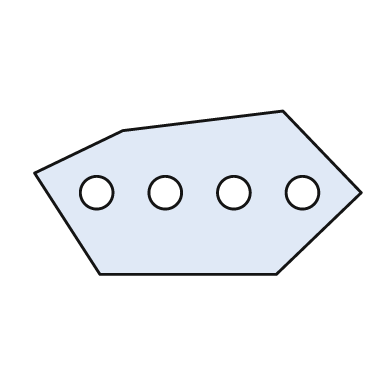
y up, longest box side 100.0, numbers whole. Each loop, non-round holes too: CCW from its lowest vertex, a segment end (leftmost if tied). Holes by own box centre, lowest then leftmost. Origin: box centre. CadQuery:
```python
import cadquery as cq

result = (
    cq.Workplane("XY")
    .moveTo(-30.0, -25.0)
    .lineTo(24.0, -25.0)
    .lineTo(50.0, 0.0)
    .lineTo(26.0, 25.0)
    .lineTo(-23.0, 19.0)
    .lineTo(-50.0, 6.0)
    .close()
    .moveTo(-31.0, 0.0)
    .circle(5.0)
    .moveTo(-10.0, 0.0)
    .circle(5.0)
    .moveTo(11.0, 0.0)
    .circle(5.0)
    .moveTo(32.0, 0.0)
    .circle(5.0)
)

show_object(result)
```